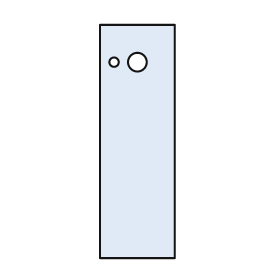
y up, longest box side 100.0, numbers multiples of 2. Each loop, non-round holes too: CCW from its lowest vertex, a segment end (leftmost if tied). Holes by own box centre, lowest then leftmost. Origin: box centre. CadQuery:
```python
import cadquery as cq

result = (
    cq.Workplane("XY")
    .moveTo(-16.0, -50.0)
    .lineTo(16.0, -50.0)
    .lineTo(16.0, 50.0)
    .lineTo(-16.0, 50.0)
    .close()
    .moveTo(-10.0, 34.0)
    .circle(2.0)
    .moveTo(0.0, 34.0)
    .circle(4.0)
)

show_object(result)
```